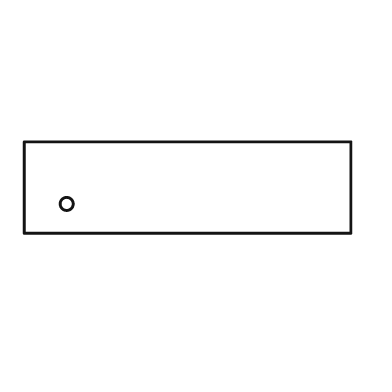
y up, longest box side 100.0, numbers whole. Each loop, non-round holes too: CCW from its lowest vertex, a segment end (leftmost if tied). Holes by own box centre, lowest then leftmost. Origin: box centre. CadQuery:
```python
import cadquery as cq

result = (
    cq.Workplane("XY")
    .moveTo(-50.0, -14.0)
    .lineTo(50.0, -14.0)
    .lineTo(50.0, 14.0)
    .lineTo(-50.0, 14.0)
    .close()
    .moveTo(-37.0, -5.0)
    .circle(2.0)
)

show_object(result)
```